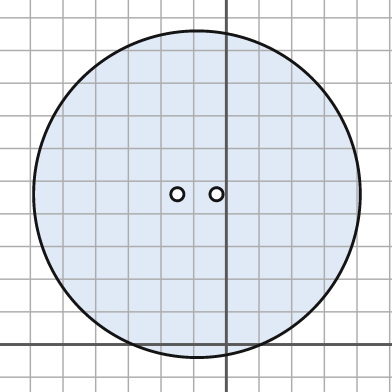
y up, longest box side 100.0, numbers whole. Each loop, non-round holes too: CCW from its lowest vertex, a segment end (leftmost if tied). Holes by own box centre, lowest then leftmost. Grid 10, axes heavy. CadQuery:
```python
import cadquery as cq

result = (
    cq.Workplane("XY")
    .moveTo(-9.0, 46.0)
    .circle(50.0)
    .moveTo(-15.0, 46.0)
    .circle(2.0)
    .moveTo(-3.0, 46.0)
    .circle(2.0)
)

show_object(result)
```